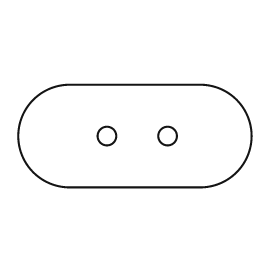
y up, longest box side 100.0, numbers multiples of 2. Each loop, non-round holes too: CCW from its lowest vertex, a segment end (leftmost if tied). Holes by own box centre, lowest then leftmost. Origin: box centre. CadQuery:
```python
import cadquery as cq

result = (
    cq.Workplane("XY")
    .moveTo(-28.0, -22.0)
    .lineTo(28.0, -22.0)
    .threePointArc((50.0, 0.0), (28.0, 22.0))
    .lineTo(-28.0, 22.0)
    .threePointArc((-50.0, 0.0), (-28.0, -22.0))
    .close()
    .moveTo(-12.0, 0.0)
    .circle(4.0)
    .moveTo(14.0, 0.0)
    .circle(4.0)
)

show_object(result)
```